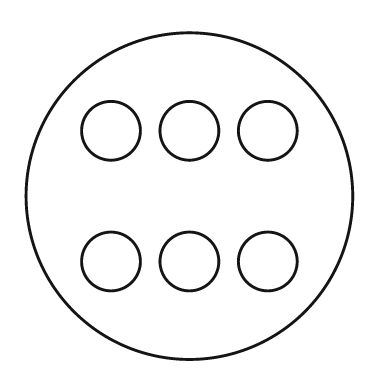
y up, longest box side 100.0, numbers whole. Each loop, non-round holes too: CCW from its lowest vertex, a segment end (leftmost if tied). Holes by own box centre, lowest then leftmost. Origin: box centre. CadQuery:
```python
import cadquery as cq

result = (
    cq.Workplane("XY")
    .moveTo(0.0, 0.0)
    .circle(50.0)
    .moveTo(-24.0, -20.0)
    .circle(9.0)
    .moveTo(0.0, -20.0)
    .circle(9.0)
    .moveTo(24.0, -20.0)
    .circle(9.0)
    .moveTo(-24.0, 20.0)
    .circle(9.0)
    .moveTo(0.0, 20.0)
    .circle(9.0)
    .moveTo(24.0, 20.0)
    .circle(9.0)
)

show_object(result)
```